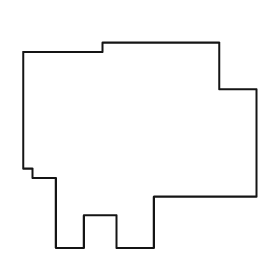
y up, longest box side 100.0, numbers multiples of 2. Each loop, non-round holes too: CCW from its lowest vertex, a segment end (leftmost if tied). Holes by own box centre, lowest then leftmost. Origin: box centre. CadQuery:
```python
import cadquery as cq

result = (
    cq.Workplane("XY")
    .moveTo(-36.0, -44.0)
    .lineTo(-24.0, -44.0)
    .lineTo(-24.0, -30.0)
    .lineTo(-10.0, -30.0)
    .lineTo(-10.0, -44.0)
    .lineTo(6.0, -44.0)
    .lineTo(6.0, -22.0)
    .lineTo(50.0, -22.0)
    .lineTo(50.0, 24.0)
    .lineTo(34.0, 24.0)
    .lineTo(34.0, 44.0)
    .lineTo(-16.0, 44.0)
    .lineTo(-16.0, 40.0)
    .lineTo(-50.0, 40.0)
    .lineTo(-50.0, -10.0)
    .lineTo(-46.0, -10.0)
    .lineTo(-46.0, -14.0)
    .lineTo(-36.0, -14.0)
    .close()
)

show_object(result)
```